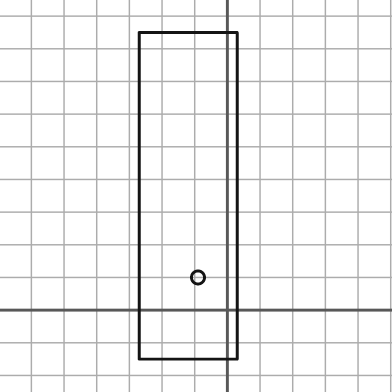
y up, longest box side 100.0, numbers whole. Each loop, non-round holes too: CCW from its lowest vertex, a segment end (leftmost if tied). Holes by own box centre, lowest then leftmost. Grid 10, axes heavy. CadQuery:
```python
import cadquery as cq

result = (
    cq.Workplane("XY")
    .moveTo(-27.0, -15.0)
    .lineTo(3.0, -15.0)
    .lineTo(3.0, 85.0)
    .lineTo(-27.0, 85.0)
    .close()
    .moveTo(-9.0, 10.0)
    .circle(2.0)
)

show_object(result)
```